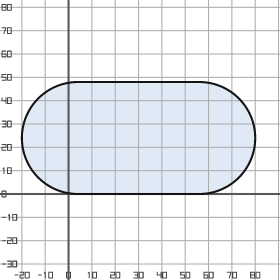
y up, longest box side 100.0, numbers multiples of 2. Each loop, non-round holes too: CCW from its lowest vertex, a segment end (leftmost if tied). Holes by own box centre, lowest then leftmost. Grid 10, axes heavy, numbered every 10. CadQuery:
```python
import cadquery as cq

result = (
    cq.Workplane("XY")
    .moveTo(4.0, 0.0)
    .lineTo(56.0, 0.0)
    .threePointArc((80.0, 24.0), (56.0, 48.0))
    .lineTo(4.0, 48.0)
    .threePointArc((-20.0, 24.0), (4.0, 0.0))
    .close()
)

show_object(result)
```